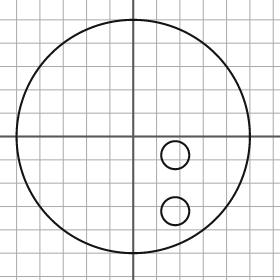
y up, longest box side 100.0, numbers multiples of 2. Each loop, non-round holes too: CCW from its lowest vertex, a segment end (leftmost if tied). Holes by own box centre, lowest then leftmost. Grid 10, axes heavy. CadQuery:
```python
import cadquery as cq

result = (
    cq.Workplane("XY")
    .moveTo(0.0, 0.0)
    .circle(50.0)
    .moveTo(18.0, -32.0)
    .circle(6.0)
    .moveTo(18.0, -8.0)
    .circle(6.0)
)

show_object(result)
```